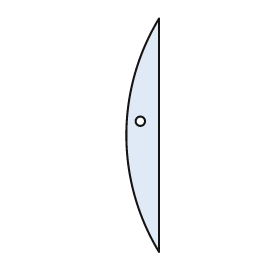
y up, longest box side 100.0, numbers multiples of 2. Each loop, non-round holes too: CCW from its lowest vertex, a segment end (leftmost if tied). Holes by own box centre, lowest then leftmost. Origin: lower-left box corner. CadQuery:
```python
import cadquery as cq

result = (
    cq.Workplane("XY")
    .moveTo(14.0, 0.0)
    .lineTo(14.0, 100.0)
    .threePointArc((0.0, 50.0), (14.0, 0.0))
    .close()
    .moveTo(6.0, 56.0)
    .circle(2.0)
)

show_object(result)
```